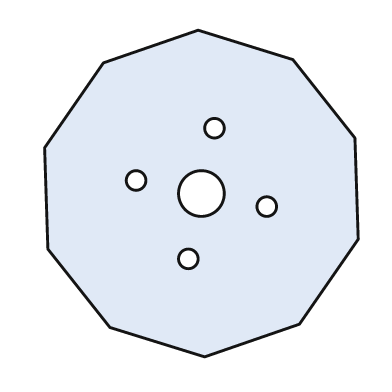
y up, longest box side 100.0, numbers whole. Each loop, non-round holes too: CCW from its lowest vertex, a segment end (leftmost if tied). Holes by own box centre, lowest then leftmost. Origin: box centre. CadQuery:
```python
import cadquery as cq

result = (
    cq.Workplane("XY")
    .moveTo(1.0, -50.0)
    .lineTo(30.0, -40.0)
    .lineTo(48.0, -14.0)
    .lineTo(47.0, 17.0)
    .lineTo(28.0, 41.0)
    .lineTo(-1.0, 50.0)
    .lineTo(-30.0, 40.0)
    .lineTo(-48.0, 14.0)
    .lineTo(-47.0, -17.0)
    .lineTo(-28.0, -41.0)
    .close()
    .moveTo(-4.0, -20.0)
    .circle(3.0)
    .moveTo(20.0, -4.0)
    .circle(3.0)
    .moveTo(0.0, 0.0)
    .circle(7.0)
    .moveTo(-20.0, 4.0)
    .circle(3.0)
    .moveTo(4.0, 20.0)
    .circle(3.0)
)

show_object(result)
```